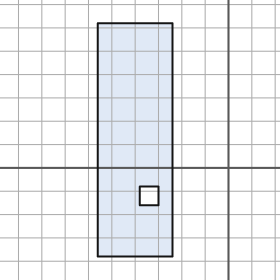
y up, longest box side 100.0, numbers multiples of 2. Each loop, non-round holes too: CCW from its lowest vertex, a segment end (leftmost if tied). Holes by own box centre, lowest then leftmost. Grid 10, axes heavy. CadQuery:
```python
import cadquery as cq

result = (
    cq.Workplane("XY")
    .moveTo(-56.0, -38.0)
    .lineTo(-24.0, -38.0)
    .lineTo(-24.0, 62.0)
    .lineTo(-56.0, 62.0)
    .close()
    .moveTo(-38.0, -16.0)
    .lineTo(-30.0, -16.0)
    .lineTo(-30.0, -8.0)
    .lineTo(-38.0, -8.0)
    .close()
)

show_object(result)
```